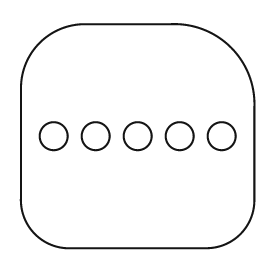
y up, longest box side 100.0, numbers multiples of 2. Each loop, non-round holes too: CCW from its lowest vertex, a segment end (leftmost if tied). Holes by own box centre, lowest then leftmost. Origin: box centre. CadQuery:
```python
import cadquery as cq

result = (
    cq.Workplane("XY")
    .moveTo(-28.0, -48.0)
    .lineTo(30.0, -48.0)
    .threePointArc((44.0, -42.0), (50.0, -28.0))
    .lineTo(50.0, 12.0)
    .threePointArc((40.0, 38.0), (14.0, 48.0))
    .lineTo(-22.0, 48.0)
    .threePointArc((-42.0, 40.0), (-50.0, 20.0))
    .lineTo(-50.0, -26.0)
    .threePointArc((-44.0, -42.0), (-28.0, -48.0))
    .close()
    .moveTo(-36.0, 0.0)
    .circle(6.0)
    .moveTo(-18.0, 0.0)
    .circle(6.0)
    .moveTo(0.0, 0.0)
    .circle(6.0)
    .moveTo(18.0, 0.0)
    .circle(6.0)
    .moveTo(36.0, 0.0)
    .circle(6.0)
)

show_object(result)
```